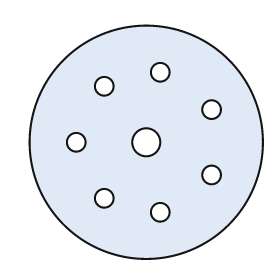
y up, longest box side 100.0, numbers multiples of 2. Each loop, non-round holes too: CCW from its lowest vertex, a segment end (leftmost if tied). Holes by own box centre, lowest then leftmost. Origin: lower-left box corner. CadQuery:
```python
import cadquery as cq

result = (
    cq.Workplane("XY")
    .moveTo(50.0, 50.0)
    .circle(50.0)
    .moveTo(56.0, 20.0)
    .circle(4.0)
    .moveTo(32.0, 26.0)
    .circle(4.0)
    .moveTo(78.0, 36.0)
    .circle(4.0)
    .moveTo(20.0, 50.0)
    .circle(4.0)
    .moveTo(50.0, 50.0)
    .circle(6.0)
    .moveTo(78.0, 64.0)
    .circle(4.0)
    .moveTo(32.0, 74.0)
    .circle(4.0)
    .moveTo(56.0, 80.0)
    .circle(4.0)
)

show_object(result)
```